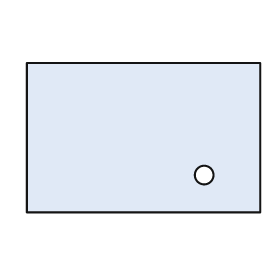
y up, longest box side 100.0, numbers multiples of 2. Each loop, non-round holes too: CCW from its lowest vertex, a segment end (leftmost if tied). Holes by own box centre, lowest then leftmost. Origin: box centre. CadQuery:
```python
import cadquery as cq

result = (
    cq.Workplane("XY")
    .moveTo(-50.0, -32.0)
    .lineTo(50.0, -32.0)
    .lineTo(50.0, 32.0)
    .lineTo(-50.0, 32.0)
    .close()
    .moveTo(26.0, -16.0)
    .circle(4.0)
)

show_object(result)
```